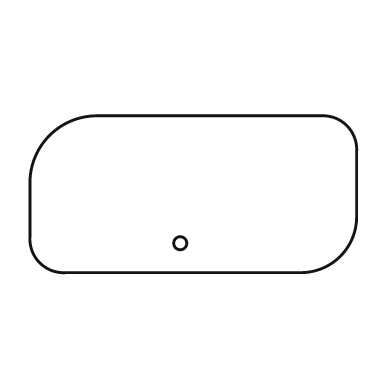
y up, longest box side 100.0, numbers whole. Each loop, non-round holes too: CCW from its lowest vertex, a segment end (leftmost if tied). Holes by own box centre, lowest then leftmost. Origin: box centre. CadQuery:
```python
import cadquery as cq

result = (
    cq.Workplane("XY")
    .moveTo(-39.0, -24.0)
    .lineTo(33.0, -24.0)
    .threePointArc((45.0, -19.0), (50.0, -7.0))
    .lineTo(50.0, 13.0)
    .threePointArc((47.0, 21.0), (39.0, 24.0))
    .lineTo(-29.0, 24.0)
    .threePointArc((-44.0, 18.0), (-50.0, 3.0))
    .lineTo(-50.0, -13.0)
    .threePointArc((-47.0, -21.0), (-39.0, -24.0))
    .close()
    .moveTo(-4.0, -15.0)
    .circle(2.0)
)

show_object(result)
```